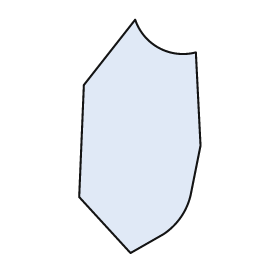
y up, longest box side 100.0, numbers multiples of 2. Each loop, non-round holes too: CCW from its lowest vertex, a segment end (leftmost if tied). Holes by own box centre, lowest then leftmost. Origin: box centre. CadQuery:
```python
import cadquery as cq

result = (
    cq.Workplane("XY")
    .moveTo(-4.0, -50.0)
    .lineTo(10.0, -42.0)
    .threePointArc((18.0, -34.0), (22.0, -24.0))
    .lineTo(26.0, -4.0)
    .lineTo(24.0, 36.0)
    .threePointArc((8.0, 38.0), (-2.0, 50.0))
    .lineTo(-24.0, 22.0)
    .lineTo(-26.0, -26.0)
    .close()
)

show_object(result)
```